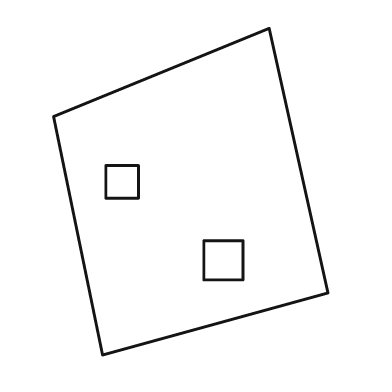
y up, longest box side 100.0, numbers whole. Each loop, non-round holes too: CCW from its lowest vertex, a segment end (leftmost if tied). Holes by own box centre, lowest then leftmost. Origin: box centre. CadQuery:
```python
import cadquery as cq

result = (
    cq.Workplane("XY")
    .moveTo(-27.0, -50.0)
    .lineTo(42.0, -31.0)
    .lineTo(24.0, 50.0)
    .lineTo(-42.0, 23.0)
    .close()
    .moveTo(4.0, -27.0)
    .lineTo(16.0, -27.0)
    .lineTo(16.0, -15.0)
    .lineTo(4.0, -15.0)
    .close()
    .moveTo(-26.0, -2.0)
    .lineTo(-16.0, -2.0)
    .lineTo(-16.0, 8.0)
    .lineTo(-26.0, 8.0)
    .close()
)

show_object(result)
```